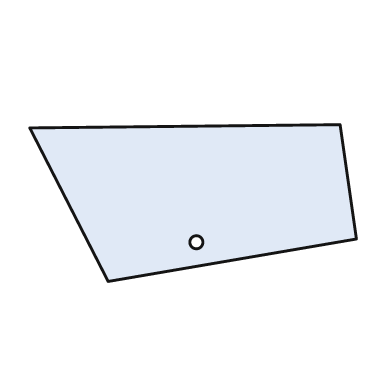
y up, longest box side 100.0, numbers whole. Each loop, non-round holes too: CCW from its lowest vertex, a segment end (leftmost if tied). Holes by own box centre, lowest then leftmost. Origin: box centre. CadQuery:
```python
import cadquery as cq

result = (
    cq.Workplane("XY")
    .moveTo(-26.0, -24.0)
    .lineTo(50.0, -11.0)
    .lineTo(45.0, 24.0)
    .lineTo(-50.0, 23.0)
    .close()
    .moveTo(1.0, -12.0)
    .circle(2.0)
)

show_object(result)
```